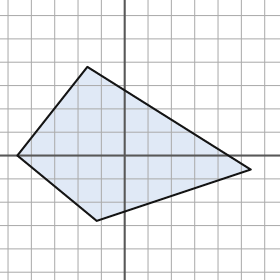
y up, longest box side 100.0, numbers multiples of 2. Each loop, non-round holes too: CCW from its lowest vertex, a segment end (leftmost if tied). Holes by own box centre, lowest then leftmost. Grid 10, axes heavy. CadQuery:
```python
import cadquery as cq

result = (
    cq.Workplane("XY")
    .moveTo(-12.0, -28.0)
    .lineTo(54.0, -6.0)
    .lineTo(-16.0, 38.0)
    .lineTo(-46.0, 0.0)
    .close()
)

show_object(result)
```